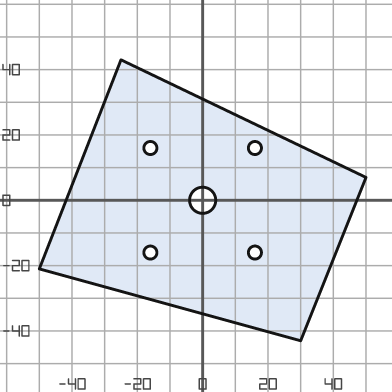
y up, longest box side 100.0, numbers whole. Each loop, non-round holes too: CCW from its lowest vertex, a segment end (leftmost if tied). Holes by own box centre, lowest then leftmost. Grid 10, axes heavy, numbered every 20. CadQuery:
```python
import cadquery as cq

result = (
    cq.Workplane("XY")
    .moveTo(30.0, -43.0)
    .lineTo(50.0, 7.0)
    .lineTo(-25.0, 43.0)
    .lineTo(-50.0, -21.0)
    .close()
    .moveTo(-16.0, -16.0)
    .circle(2.0)
    .moveTo(16.0, -16.0)
    .circle(2.0)
    .moveTo(0.0, 0.0)
    .circle(4.0)
    .moveTo(-16.0, 16.0)
    .circle(2.0)
    .moveTo(16.0, 16.0)
    .circle(2.0)
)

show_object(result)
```